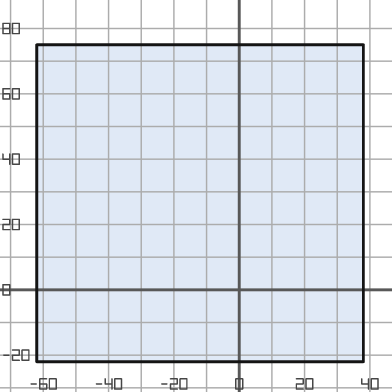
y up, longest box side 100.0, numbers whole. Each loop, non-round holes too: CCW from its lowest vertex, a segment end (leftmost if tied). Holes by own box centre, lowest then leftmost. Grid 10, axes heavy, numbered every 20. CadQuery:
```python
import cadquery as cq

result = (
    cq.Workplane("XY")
    .moveTo(-62.0, -22.0)
    .lineTo(38.0, -22.0)
    .lineTo(38.0, 75.0)
    .lineTo(-62.0, 75.0)
    .close()
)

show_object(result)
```